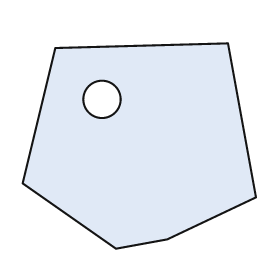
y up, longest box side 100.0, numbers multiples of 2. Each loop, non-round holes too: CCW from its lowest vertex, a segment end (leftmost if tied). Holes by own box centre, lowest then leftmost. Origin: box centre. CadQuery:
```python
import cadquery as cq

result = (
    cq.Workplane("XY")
    .moveTo(-10.0, -44.0)
    .lineTo(12.0, -40.0)
    .lineTo(50.0, -22.0)
    .lineTo(38.0, 44.0)
    .lineTo(-36.0, 42.0)
    .lineTo(-50.0, -16.0)
    .close()
    .moveTo(-16.0, 20.0)
    .circle(8.0)
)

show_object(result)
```